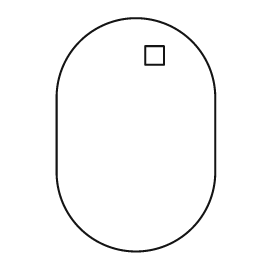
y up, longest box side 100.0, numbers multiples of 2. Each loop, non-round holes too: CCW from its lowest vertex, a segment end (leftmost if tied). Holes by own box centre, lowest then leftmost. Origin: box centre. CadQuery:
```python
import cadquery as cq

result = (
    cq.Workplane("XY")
    .moveTo(-34.0, -16.0)
    .threePointArc((0.0, -50.0), (34.0, -16.0))
    .lineTo(34.0, 16.0)
    .threePointArc((0.0, 50.0), (-34.0, 16.0))
    .close()
    .moveTo(4.0, 30.0)
    .lineTo(12.0, 30.0)
    .lineTo(12.0, 38.0)
    .lineTo(4.0, 38.0)
    .close()
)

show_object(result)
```